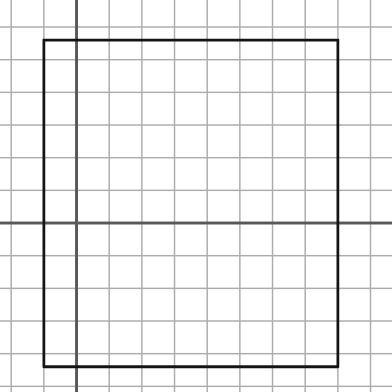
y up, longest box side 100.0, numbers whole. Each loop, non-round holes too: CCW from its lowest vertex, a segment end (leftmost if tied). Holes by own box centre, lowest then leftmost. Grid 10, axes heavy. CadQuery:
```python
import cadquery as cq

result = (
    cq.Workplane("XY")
    .moveTo(-10.0, -44.0)
    .lineTo(80.0, -44.0)
    .lineTo(80.0, 56.0)
    .lineTo(-10.0, 56.0)
    .close()
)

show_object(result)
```